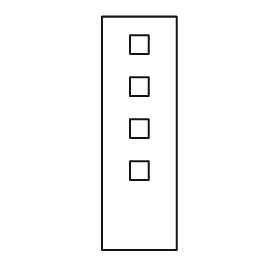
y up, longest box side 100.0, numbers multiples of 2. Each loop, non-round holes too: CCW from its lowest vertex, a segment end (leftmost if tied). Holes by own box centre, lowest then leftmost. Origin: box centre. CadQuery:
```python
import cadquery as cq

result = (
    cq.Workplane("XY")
    .moveTo(-16.0, -50.0)
    .lineTo(16.0, -50.0)
    .lineTo(16.0, 50.0)
    .lineTo(-16.0, 50.0)
    .close()
    .moveTo(-4.0, -20.0)
    .lineTo(4.0, -20.0)
    .lineTo(4.0, -12.0)
    .lineTo(-4.0, -12.0)
    .close()
    .moveTo(-4.0, -2.0)
    .lineTo(4.0, -2.0)
    .lineTo(4.0, 6.0)
    .lineTo(-4.0, 6.0)
    .close()
    .moveTo(-4.0, 16.0)
    .lineTo(4.0, 16.0)
    .lineTo(4.0, 24.0)
    .lineTo(-4.0, 24.0)
    .close()
    .moveTo(-4.0, 34.0)
    .lineTo(4.0, 34.0)
    .lineTo(4.0, 42.0)
    .lineTo(-4.0, 42.0)
    .close()
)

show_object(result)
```